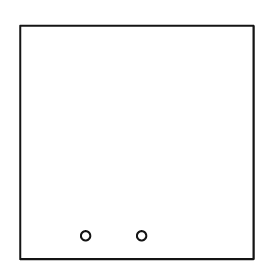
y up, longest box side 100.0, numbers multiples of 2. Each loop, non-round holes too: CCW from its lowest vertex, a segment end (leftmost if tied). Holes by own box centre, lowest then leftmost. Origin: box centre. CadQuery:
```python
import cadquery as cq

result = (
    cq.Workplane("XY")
    .moveTo(-50.0, -50.0)
    .lineTo(50.0, -50.0)
    .lineTo(50.0, 50.0)
    .lineTo(-50.0, 50.0)
    .close()
    .moveTo(-22.0, -40.0)
    .circle(2.0)
    .moveTo(2.0, -40.0)
    .circle(2.0)
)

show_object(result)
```